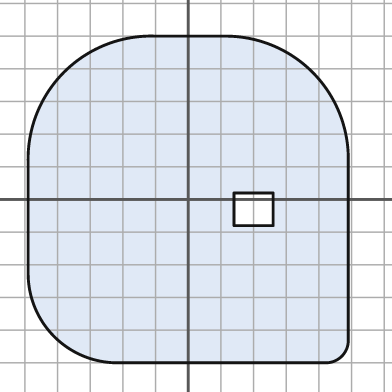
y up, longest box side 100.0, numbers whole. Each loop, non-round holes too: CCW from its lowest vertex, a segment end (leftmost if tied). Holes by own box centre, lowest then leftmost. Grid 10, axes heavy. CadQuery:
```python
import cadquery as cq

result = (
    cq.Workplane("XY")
    .moveTo(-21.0, -50.0)
    .lineTo(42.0, -50.0)
    .threePointArc((47.0, -48.0), (49.0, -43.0))
    .lineTo(49.0, 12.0)
    .threePointArc((38.0, 39.0), (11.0, 50.0))
    .lineTo(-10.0, 50.0)
    .threePointArc((-38.0, 39.0), (-49.0, 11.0))
    .lineTo(-49.0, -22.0)
    .threePointArc((-41.0, -42.0), (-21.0, -50.0))
    .close()
    .moveTo(14.0, -8.0)
    .lineTo(26.0, -8.0)
    .lineTo(26.0, 2.0)
    .lineTo(14.0, 2.0)
    .close()
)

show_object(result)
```